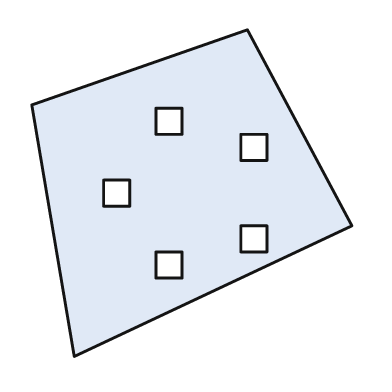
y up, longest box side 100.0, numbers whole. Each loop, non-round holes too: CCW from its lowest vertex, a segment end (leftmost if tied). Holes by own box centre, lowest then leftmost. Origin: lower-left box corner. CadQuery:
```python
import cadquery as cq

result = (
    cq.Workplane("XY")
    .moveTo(13.0, 0.0)
    .lineTo(98.0, 40.0)
    .lineTo(66.0, 100.0)
    .lineTo(0.0, 77.0)
    .close()
    .moveTo(38.0, 24.0)
    .lineTo(46.0, 24.0)
    .lineTo(46.0, 32.0)
    .lineTo(38.0, 32.0)
    .close()
    .moveTo(64.0, 32.0)
    .lineTo(72.0, 32.0)
    .lineTo(72.0, 40.0)
    .lineTo(64.0, 40.0)
    .close()
    .moveTo(22.0, 46.0)
    .lineTo(30.0, 46.0)
    .lineTo(30.0, 54.0)
    .lineTo(22.0, 54.0)
    .close()
    .moveTo(64.0, 60.0)
    .lineTo(72.0, 60.0)
    .lineTo(72.0, 68.0)
    .lineTo(64.0, 68.0)
    .close()
    .moveTo(38.0, 68.0)
    .lineTo(46.0, 68.0)
    .lineTo(46.0, 76.0)
    .lineTo(38.0, 76.0)
    .close()
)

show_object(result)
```